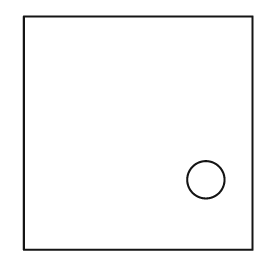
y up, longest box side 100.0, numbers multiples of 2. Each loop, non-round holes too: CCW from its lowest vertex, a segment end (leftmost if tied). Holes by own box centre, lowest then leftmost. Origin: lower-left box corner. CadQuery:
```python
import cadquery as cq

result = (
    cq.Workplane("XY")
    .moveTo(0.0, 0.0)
    .lineTo(98.0, 0.0)
    .lineTo(98.0, 100.0)
    .lineTo(0.0, 100.0)
    .close()
    .moveTo(78.0, 30.0)
    .circle(8.0)
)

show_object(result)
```